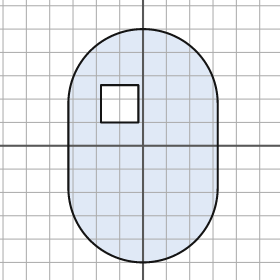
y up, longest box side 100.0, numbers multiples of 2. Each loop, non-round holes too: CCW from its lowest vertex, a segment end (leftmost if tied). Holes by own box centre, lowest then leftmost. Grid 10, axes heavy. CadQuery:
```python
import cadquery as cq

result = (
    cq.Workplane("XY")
    .moveTo(-32.0, -18.0)
    .threePointArc((0.0, -50.0), (32.0, -18.0))
    .lineTo(32.0, 18.0)
    .threePointArc((0.0, 50.0), (-32.0, 18.0))
    .close()
    .moveTo(-18.0, 10.0)
    .lineTo(-2.0, 10.0)
    .lineTo(-2.0, 26.0)
    .lineTo(-18.0, 26.0)
    .close()
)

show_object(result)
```